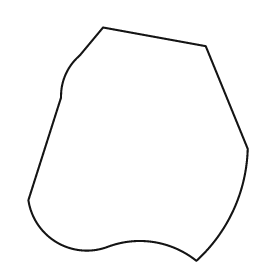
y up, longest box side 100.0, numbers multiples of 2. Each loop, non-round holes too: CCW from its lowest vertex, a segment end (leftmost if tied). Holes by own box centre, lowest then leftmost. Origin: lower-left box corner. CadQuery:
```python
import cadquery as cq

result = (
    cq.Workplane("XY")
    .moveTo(72.0, 0.0)
    .threePointArc((88.0, 22.0), (94.0, 48.0))
    .lineTo(76.0, 92.0)
    .lineTo(32.0, 100.0)
    .lineTo(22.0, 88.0)
    .threePointArc((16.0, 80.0), (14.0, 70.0))
    .lineTo(0.0, 26.0)
    .threePointArc((12.0, 8.0), (34.0, 6.0))
    .threePointArc((54.0, 8.0), (72.0, 0.0))
    .close()
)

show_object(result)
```